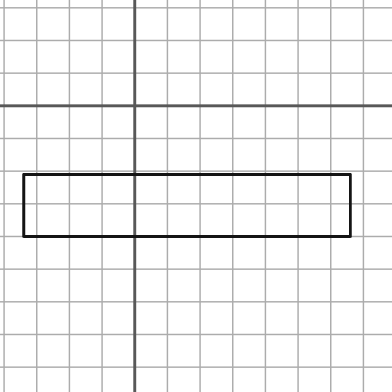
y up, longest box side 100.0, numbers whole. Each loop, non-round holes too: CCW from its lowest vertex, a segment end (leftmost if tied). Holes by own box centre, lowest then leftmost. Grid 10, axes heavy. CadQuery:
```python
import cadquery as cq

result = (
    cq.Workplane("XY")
    .moveTo(-34.0, -40.0)
    .lineTo(66.0, -40.0)
    .lineTo(66.0, -21.0)
    .lineTo(-34.0, -21.0)
    .close()
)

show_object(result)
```